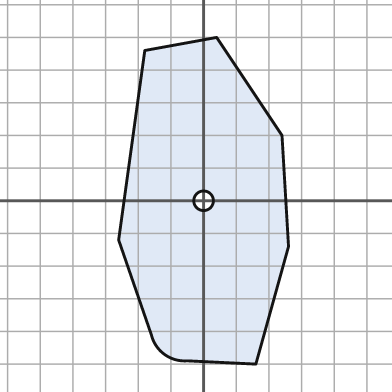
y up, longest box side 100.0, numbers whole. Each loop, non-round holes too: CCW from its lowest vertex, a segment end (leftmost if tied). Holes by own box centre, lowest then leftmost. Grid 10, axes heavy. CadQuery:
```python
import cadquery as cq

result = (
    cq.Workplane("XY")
    .moveTo(16.0, -50.0)
    .lineTo(26.0, -14.0)
    .lineTo(24.0, 20.0)
    .lineTo(4.0, 50.0)
    .lineTo(-18.0, 46.0)
    .lineTo(-26.0, -12.0)
    .lineTo(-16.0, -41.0)
    .threePointArc((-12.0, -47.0), (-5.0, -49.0))
    .close()
    .moveTo(0.0, 0.0)
    .circle(3.0)
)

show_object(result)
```